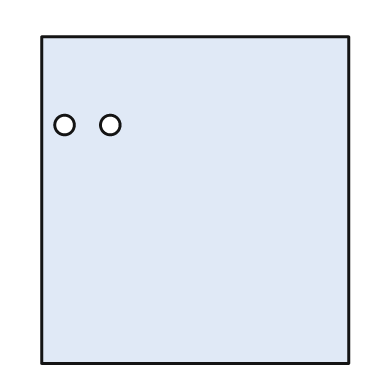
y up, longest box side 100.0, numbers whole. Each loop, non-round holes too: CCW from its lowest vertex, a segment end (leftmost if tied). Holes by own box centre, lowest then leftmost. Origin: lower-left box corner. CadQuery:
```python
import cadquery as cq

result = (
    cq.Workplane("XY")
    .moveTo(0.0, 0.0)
    .lineTo(94.0, 0.0)
    .lineTo(94.0, 100.0)
    .lineTo(0.0, 100.0)
    .close()
    .moveTo(7.0, 73.0)
    .circle(3.0)
    .moveTo(21.0, 73.0)
    .circle(3.0)
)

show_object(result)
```